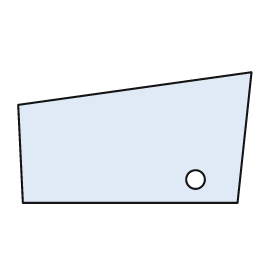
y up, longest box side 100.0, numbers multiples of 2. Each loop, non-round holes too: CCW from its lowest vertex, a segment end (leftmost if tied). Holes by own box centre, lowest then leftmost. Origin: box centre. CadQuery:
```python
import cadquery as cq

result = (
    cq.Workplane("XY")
    .moveTo(-48.0, -28.0)
    .lineTo(44.0, -28.0)
    .lineTo(50.0, 28.0)
    .lineTo(-50.0, 14.0)
    .close()
    .moveTo(26.0, -18.0)
    .circle(4.0)
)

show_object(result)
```